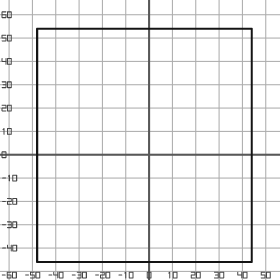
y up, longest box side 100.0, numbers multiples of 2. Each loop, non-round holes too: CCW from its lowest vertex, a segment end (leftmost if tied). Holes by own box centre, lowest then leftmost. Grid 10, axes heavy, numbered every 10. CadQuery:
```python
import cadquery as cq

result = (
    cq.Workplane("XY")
    .moveTo(-48.0, -46.0)
    .lineTo(44.0, -46.0)
    .lineTo(44.0, 54.0)
    .lineTo(-48.0, 54.0)
    .close()
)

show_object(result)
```